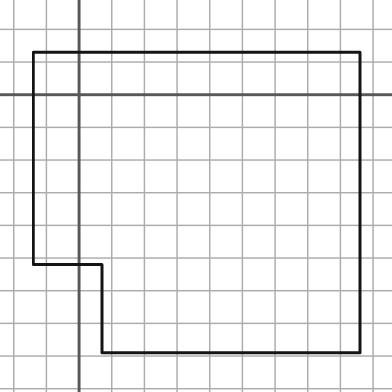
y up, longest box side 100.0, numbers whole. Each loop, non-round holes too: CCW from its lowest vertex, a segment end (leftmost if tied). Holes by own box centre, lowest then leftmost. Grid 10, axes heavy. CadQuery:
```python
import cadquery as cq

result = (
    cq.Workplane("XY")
    .moveTo(7.0, -79.0)
    .lineTo(86.0, -79.0)
    .lineTo(86.0, 13.0)
    .lineTo(-14.0, 13.0)
    .lineTo(-14.0, -52.0)
    .lineTo(7.0, -52.0)
    .close()
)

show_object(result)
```